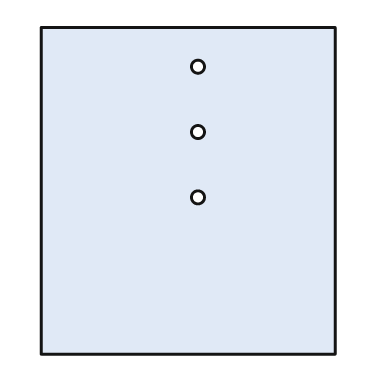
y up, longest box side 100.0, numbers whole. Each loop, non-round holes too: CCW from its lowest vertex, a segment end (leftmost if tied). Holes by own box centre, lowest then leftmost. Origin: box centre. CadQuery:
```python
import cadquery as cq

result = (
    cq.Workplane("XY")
    .moveTo(-45.0, -50.0)
    .lineTo(45.0, -50.0)
    .lineTo(45.0, 50.0)
    .lineTo(-45.0, 50.0)
    .close()
    .moveTo(3.0, -2.0)
    .circle(2.0)
    .moveTo(3.0, 18.0)
    .circle(2.0)
    .moveTo(3.0, 38.0)
    .circle(2.0)
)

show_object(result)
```